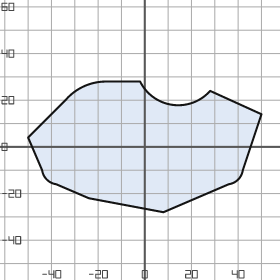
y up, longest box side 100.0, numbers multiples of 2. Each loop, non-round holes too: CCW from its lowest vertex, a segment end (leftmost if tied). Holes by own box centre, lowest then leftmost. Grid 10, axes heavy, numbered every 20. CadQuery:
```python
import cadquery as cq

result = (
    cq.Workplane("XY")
    .moveTo(8.0, -28.0)
    .lineTo(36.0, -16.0)
    .threePointArc((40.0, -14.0), (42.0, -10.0))
    .lineTo(50.0, 14.0)
    .lineTo(28.0, 24.0)
    .threePointArc((12.0, 18.0), (-2.0, 28.0))
    .lineTo(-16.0, 28.0)
    .threePointArc((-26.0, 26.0), (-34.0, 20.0))
    .lineTo(-50.0, 4.0)
    .lineTo(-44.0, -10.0)
    .threePointArc((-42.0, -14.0), (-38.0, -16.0))
    .lineTo(-24.0, -22.0)
    .close()
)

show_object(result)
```